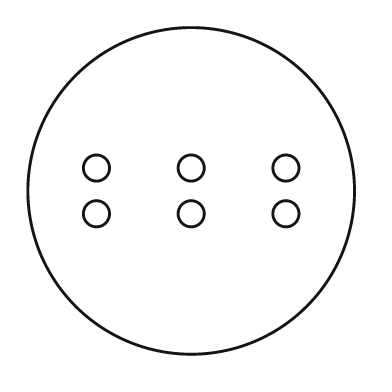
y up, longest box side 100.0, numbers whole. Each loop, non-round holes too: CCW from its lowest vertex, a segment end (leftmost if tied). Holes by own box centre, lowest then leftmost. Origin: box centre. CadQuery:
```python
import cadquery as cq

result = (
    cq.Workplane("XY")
    .moveTo(0.0, 0.0)
    .circle(50.0)
    .moveTo(-29.0, -7.0)
    .circle(4.0)
    .moveTo(0.0, -7.0)
    .circle(4.0)
    .moveTo(29.0, -7.0)
    .circle(4.0)
    .moveTo(-29.0, 7.0)
    .circle(4.0)
    .moveTo(0.0, 7.0)
    .circle(4.0)
    .moveTo(29.0, 7.0)
    .circle(4.0)
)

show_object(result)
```